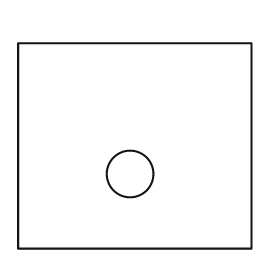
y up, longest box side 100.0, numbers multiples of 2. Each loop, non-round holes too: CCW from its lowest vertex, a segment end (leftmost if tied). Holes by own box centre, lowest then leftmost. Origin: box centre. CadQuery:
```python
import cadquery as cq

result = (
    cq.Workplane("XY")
    .moveTo(-50.0, -44.0)
    .lineTo(50.0, -44.0)
    .lineTo(50.0, 44.0)
    .lineTo(-50.0, 44.0)
    .close()
    .moveTo(-2.0, -12.0)
    .circle(10.0)
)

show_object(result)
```